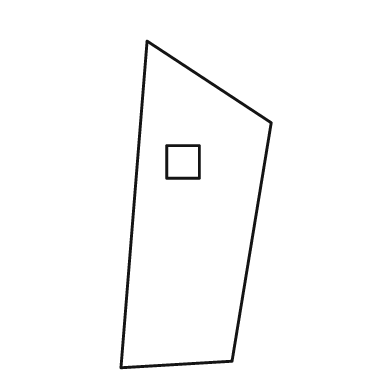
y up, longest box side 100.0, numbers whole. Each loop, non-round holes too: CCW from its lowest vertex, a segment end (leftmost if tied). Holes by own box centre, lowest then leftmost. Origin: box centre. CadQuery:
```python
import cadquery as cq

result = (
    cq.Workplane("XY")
    .moveTo(-23.0, -50.0)
    .lineTo(11.0, -48.0)
    .lineTo(23.0, 25.0)
    .lineTo(-15.0, 50.0)
    .close()
    .moveTo(-9.0, 8.0)
    .lineTo(1.0, 8.0)
    .lineTo(1.0, 18.0)
    .lineTo(-9.0, 18.0)
    .close()
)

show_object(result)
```